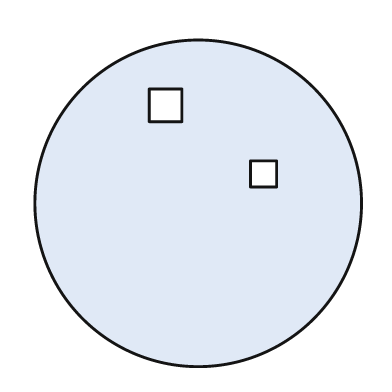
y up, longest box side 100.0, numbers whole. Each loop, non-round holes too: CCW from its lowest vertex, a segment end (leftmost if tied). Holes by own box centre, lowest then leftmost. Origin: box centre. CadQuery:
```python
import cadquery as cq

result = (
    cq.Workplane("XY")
    .moveTo(0.0, 0.0)
    .circle(50.0)
    .moveTo(16.0, 5.0)
    .lineTo(24.0, 5.0)
    .lineTo(24.0, 13.0)
    .lineTo(16.0, 13.0)
    .close()
    .moveTo(-15.0, 25.0)
    .lineTo(-5.0, 25.0)
    .lineTo(-5.0, 35.0)
    .lineTo(-15.0, 35.0)
    .close()
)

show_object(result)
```